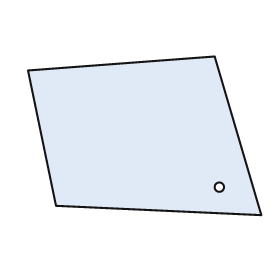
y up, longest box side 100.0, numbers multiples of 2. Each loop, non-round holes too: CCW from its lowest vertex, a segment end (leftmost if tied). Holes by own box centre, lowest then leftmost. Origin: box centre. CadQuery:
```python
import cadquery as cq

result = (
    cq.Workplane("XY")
    .moveTo(50.0, -34.0)
    .lineTo(30.0, 34.0)
    .lineTo(-50.0, 28.0)
    .lineTo(-38.0, -30.0)
    .close()
    .moveTo(32.0, -22.0)
    .circle(2.0)
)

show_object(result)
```